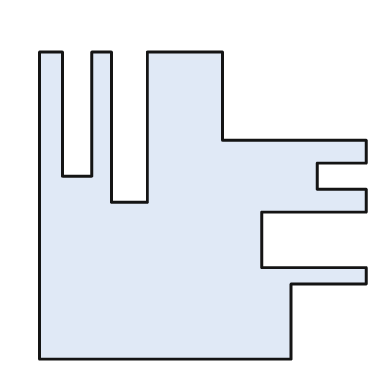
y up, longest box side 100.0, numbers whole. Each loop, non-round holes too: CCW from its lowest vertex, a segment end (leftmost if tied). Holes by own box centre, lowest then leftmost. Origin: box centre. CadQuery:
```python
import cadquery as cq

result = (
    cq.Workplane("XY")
    .moveTo(-50.0, -47.0)
    .lineTo(27.0, -47.0)
    .lineTo(27.0, -24.0)
    .lineTo(50.0, -24.0)
    .lineTo(50.0, -19.0)
    .lineTo(18.0, -19.0)
    .lineTo(18.0, -2.0)
    .lineTo(50.0, -2.0)
    .lineTo(50.0, 5.0)
    .lineTo(35.0, 5.0)
    .lineTo(35.0, 13.0)
    .lineTo(50.0, 13.0)
    .lineTo(50.0, 20.0)
    .lineTo(6.0, 20.0)
    .lineTo(6.0, 47.0)
    .lineTo(-17.0, 47.0)
    .lineTo(-17.0, 1.0)
    .lineTo(-28.0, 1.0)
    .lineTo(-28.0, 47.0)
    .lineTo(-34.0, 47.0)
    .lineTo(-34.0, 9.0)
    .lineTo(-43.0, 9.0)
    .lineTo(-43.0, 47.0)
    .lineTo(-50.0, 47.0)
    .close()
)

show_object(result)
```